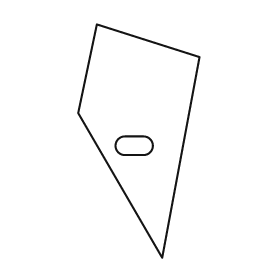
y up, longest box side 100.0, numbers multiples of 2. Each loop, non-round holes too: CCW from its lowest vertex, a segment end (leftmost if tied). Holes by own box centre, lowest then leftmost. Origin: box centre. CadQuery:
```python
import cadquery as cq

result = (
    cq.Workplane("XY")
    .moveTo(10.0, -50.0)
    .lineTo(26.0, 36.0)
    .lineTo(-18.0, 50.0)
    .lineTo(-26.0, 12.0)
    .close()
    .moveTo(-6.0, -6.0)
    .lineTo(2.0, -6.0)
    .threePointArc((6.0, -2.0), (2.0, 2.0))
    .lineTo(-6.0, 2.0)
    .threePointArc((-10.0, -2.0), (-6.0, -6.0))
    .close()
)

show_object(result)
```